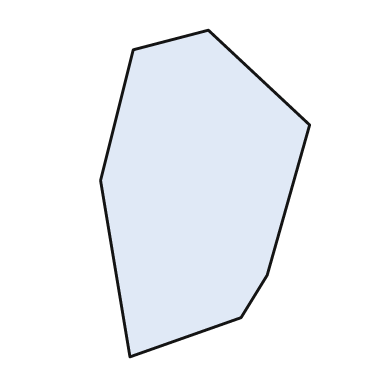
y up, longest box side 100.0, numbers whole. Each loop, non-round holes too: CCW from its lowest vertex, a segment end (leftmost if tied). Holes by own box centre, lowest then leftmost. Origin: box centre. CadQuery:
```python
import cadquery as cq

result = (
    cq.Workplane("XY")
    .moveTo(-23.0, -50.0)
    .lineTo(11.0, -38.0)
    .lineTo(19.0, -25.0)
    .lineTo(32.0, 21.0)
    .lineTo(1.0, 50.0)
    .lineTo(-22.0, 44.0)
    .lineTo(-32.0, 4.0)
    .close()
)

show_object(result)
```